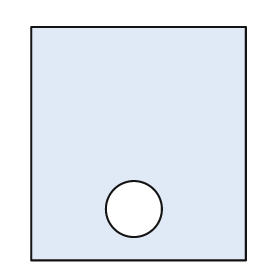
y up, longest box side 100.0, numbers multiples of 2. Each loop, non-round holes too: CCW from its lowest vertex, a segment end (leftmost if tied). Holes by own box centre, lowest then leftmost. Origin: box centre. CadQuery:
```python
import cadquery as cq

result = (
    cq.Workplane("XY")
    .moveTo(-46.0, -50.0)
    .lineTo(46.0, -50.0)
    .lineTo(46.0, 50.0)
    .lineTo(-46.0, 50.0)
    .close()
    .moveTo(-2.0, -28.0)
    .circle(12.0)
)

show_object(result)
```